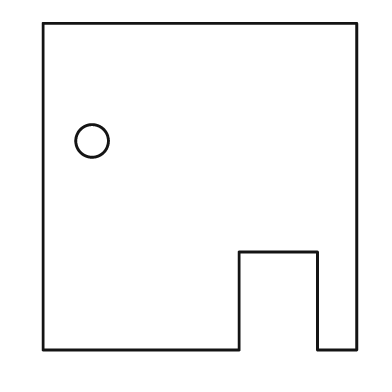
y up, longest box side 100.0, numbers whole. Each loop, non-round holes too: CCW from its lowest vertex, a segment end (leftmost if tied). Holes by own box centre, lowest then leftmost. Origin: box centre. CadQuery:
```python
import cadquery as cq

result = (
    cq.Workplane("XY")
    .moveTo(-48.0, -50.0)
    .lineTo(12.0, -50.0)
    .lineTo(12.0, -20.0)
    .lineTo(36.0, -20.0)
    .lineTo(36.0, -50.0)
    .lineTo(48.0, -50.0)
    .lineTo(48.0, 50.0)
    .lineTo(-48.0, 50.0)
    .close()
    .moveTo(-33.0, 14.0)
    .circle(5.0)
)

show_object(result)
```